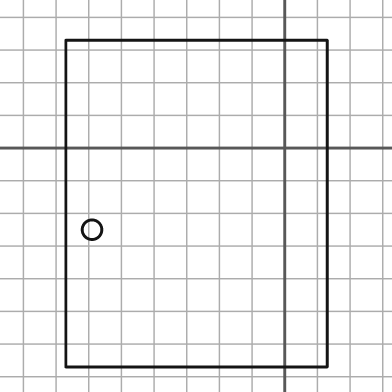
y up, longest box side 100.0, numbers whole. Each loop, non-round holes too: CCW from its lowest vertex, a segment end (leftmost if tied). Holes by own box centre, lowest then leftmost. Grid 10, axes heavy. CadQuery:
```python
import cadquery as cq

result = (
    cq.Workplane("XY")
    .moveTo(-67.0, -67.0)
    .lineTo(13.0, -67.0)
    .lineTo(13.0, 33.0)
    .lineTo(-67.0, 33.0)
    .close()
    .moveTo(-59.0, -25.0)
    .circle(3.0)
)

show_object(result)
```